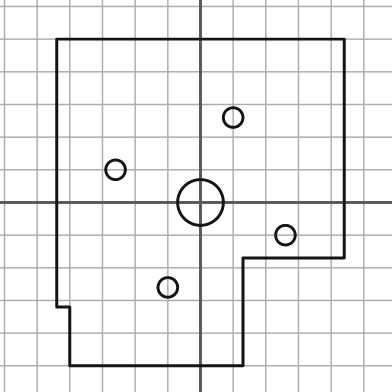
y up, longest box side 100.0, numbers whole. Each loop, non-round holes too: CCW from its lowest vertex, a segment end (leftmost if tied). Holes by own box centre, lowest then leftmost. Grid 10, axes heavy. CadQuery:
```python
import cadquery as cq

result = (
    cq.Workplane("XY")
    .moveTo(-40.0, -50.0)
    .lineTo(13.0, -50.0)
    .lineTo(13.0, -17.0)
    .lineTo(44.0, -17.0)
    .lineTo(44.0, 50.0)
    .lineTo(-44.0, 50.0)
    .lineTo(-44.0, -32.0)
    .lineTo(-40.0, -32.0)
    .close()
    .moveTo(-10.0, -26.0)
    .circle(3.0)
    .moveTo(26.0, -10.0)
    .circle(3.0)
    .moveTo(0.0, 0.0)
    .circle(7.0)
    .moveTo(-26.0, 10.0)
    .circle(3.0)
    .moveTo(10.0, 26.0)
    .circle(3.0)
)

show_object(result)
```